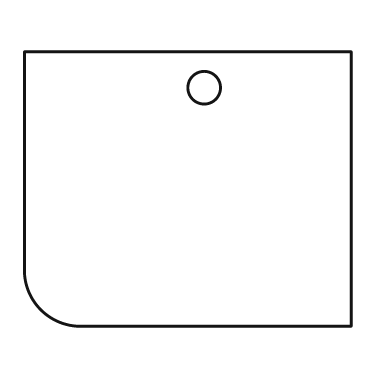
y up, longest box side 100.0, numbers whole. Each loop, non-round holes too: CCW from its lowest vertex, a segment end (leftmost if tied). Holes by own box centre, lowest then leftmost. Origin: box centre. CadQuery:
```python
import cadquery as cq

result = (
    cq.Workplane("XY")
    .moveTo(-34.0, -42.0)
    .lineTo(50.0, -42.0)
    .lineTo(50.0, 42.0)
    .lineTo(-50.0, 42.0)
    .lineTo(-50.0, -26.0)
    .threePointArc((-45.0, -37.0), (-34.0, -42.0))
    .close()
    .moveTo(5.0, 31.0)
    .circle(5.0)
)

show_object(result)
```